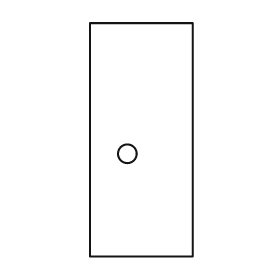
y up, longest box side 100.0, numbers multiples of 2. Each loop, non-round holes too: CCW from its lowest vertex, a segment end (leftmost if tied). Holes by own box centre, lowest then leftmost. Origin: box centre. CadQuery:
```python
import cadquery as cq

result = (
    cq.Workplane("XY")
    .moveTo(-22.0, -50.0)
    .lineTo(22.0, -50.0)
    .lineTo(22.0, 50.0)
    .lineTo(-22.0, 50.0)
    .close()
    .moveTo(-6.0, -6.0)
    .circle(4.0)
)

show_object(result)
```